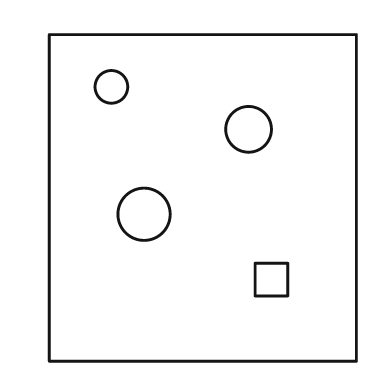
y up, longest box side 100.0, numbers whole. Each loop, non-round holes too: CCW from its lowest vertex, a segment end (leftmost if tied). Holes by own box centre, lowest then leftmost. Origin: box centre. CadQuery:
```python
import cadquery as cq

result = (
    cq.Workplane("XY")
    .moveTo(-47.0, -50.0)
    .lineTo(47.0, -50.0)
    .lineTo(47.0, 50.0)
    .lineTo(-47.0, 50.0)
    .close()
    .moveTo(16.0, -30.0)
    .lineTo(26.0, -30.0)
    .lineTo(26.0, -20.0)
    .lineTo(16.0, -20.0)
    .close()
    .moveTo(-18.0, -5.0)
    .circle(8.0)
    .moveTo(14.0, 21.0)
    .circle(7.0)
    .moveTo(-28.0, 34.0)
    .circle(5.0)
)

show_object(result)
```